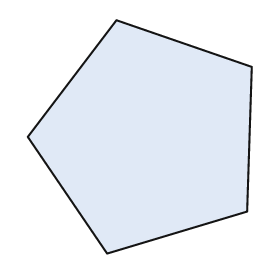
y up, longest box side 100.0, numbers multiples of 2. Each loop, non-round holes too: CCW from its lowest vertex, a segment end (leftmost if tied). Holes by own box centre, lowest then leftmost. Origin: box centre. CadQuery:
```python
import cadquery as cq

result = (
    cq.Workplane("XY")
    .moveTo(-14.0, -50.0)
    .lineTo(46.0, -32.0)
    .lineTo(48.0, 30.0)
    .lineTo(-10.0, 50.0)
    .lineTo(-48.0, 0.0)
    .close()
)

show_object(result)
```